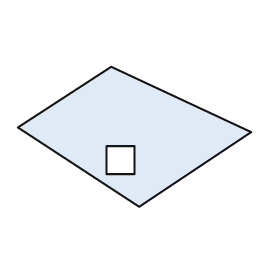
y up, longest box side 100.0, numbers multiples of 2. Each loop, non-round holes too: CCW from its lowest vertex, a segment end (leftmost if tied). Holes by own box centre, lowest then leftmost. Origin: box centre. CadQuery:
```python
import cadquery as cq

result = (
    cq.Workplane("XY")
    .moveTo(2.0, -30.0)
    .lineTo(50.0, 2.0)
    .lineTo(-10.0, 30.0)
    .lineTo(-50.0, 4.0)
    .close()
    .moveTo(-12.0, -16.0)
    .lineTo(0.0, -16.0)
    .lineTo(0.0, -4.0)
    .lineTo(-12.0, -4.0)
    .close()
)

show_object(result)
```